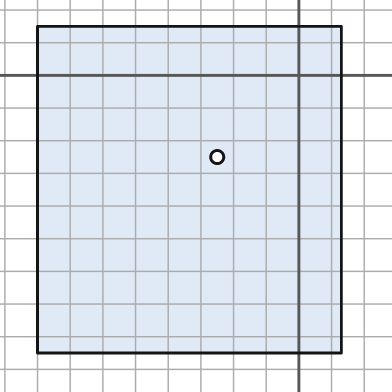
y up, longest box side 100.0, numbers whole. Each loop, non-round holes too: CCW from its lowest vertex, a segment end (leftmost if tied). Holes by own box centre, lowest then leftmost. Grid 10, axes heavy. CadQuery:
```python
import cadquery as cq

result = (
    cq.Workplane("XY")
    .moveTo(-80.0, -85.0)
    .lineTo(13.0, -85.0)
    .lineTo(13.0, 15.0)
    .lineTo(-80.0, 15.0)
    .close()
    .moveTo(-25.0, -25.0)
    .circle(2.0)
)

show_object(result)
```